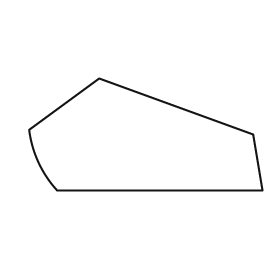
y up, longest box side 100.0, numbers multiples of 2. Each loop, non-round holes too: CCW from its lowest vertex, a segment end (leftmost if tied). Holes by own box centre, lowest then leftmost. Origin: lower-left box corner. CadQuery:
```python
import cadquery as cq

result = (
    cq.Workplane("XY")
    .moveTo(12.0, 0.0)
    .lineTo(100.0, 0.0)
    .lineTo(96.0, 24.0)
    .lineTo(30.0, 48.0)
    .lineTo(0.0, 26.0)
    .threePointArc((4.0, 12.0), (12.0, 0.0))
    .close()
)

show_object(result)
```